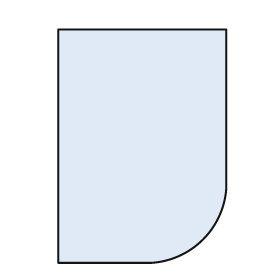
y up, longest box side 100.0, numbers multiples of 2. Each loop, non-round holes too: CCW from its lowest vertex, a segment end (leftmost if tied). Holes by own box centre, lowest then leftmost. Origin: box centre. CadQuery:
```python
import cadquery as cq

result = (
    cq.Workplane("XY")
    .moveTo(-36.0, -50.0)
    .lineTo(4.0, -50.0)
    .threePointArc((26.0, -40.0), (36.0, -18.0))
    .lineTo(36.0, 50.0)
    .lineTo(-36.0, 50.0)
    .close()
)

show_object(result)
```